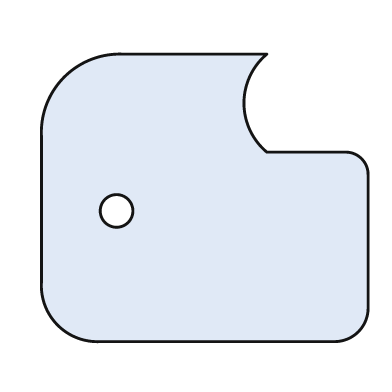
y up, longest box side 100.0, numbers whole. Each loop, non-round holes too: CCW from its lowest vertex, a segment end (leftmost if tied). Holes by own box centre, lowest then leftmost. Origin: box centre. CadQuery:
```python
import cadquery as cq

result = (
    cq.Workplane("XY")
    .moveTo(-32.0, -44.0)
    .lineTo(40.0, -44.0)
    .threePointArc((47.0, -41.0), (50.0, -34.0))
    .lineTo(50.0, 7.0)
    .threePointArc((48.0, 12.0), (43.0, 14.0))
    .lineTo(19.0, 14.0)
    .threePointArc((12.0, 29.0), (19.0, 44.0))
    .lineTo(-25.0, 44.0)
    .threePointArc((-43.0, 37.0), (-50.0, 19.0))
    .lineTo(-50.0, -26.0)
    .threePointArc((-45.0, -39.0), (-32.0, -44.0))
    .close()
    .moveTo(-27.0, -4.0)
    .circle(5.0)
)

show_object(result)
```